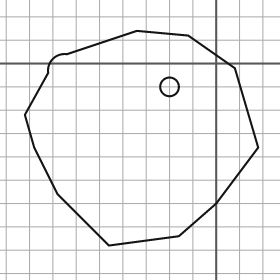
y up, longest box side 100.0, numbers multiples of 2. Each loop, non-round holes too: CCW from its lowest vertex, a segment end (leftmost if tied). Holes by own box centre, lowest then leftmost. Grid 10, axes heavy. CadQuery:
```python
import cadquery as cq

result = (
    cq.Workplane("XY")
    .moveTo(-46.0, -78.0)
    .lineTo(-16.0, -74.0)
    .lineTo(0.0, -60.0)
    .lineTo(18.0, -36.0)
    .lineTo(8.0, -2.0)
    .lineTo(-12.0, 12.0)
    .lineTo(-34.0, 14.0)
    .lineTo(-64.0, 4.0)
    .threePointArc((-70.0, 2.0), (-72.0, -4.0))
    .lineTo(-82.0, -22.0)
    .lineTo(-78.0, -36.0)
    .lineTo(-68.0, -56.0)
    .close()
    .moveTo(-20.0, -10.0)
    .circle(4.0)
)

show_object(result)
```